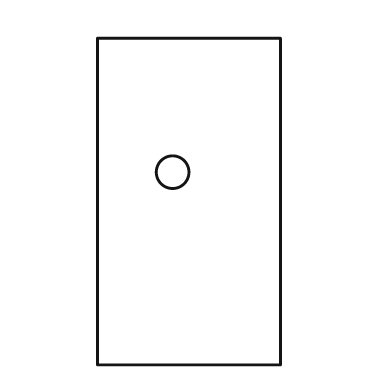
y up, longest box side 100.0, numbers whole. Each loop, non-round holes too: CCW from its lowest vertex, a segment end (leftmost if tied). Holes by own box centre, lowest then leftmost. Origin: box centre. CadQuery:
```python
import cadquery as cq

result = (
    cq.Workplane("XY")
    .moveTo(-28.0, -50.0)
    .lineTo(28.0, -50.0)
    .lineTo(28.0, 50.0)
    .lineTo(-28.0, 50.0)
    .close()
    .moveTo(-5.0, 9.0)
    .circle(5.0)
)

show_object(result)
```